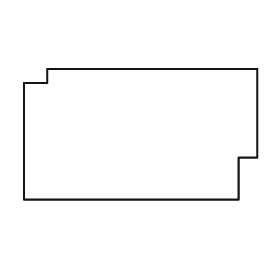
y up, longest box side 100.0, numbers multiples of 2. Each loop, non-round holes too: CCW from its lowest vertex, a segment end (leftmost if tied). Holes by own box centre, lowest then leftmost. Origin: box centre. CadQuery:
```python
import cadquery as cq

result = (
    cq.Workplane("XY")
    .moveTo(-50.0, -28.0)
    .lineTo(42.0, -28.0)
    .lineTo(42.0, -10.0)
    .lineTo(50.0, -10.0)
    .lineTo(50.0, 28.0)
    .lineTo(-40.0, 28.0)
    .lineTo(-40.0, 22.0)
    .lineTo(-50.0, 22.0)
    .close()
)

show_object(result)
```